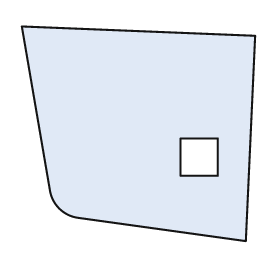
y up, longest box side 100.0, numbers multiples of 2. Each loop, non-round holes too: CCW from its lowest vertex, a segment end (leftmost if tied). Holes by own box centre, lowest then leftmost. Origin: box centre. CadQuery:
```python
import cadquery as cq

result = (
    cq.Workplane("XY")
    .moveTo(46.0, -46.0)
    .lineTo(50.0, 42.0)
    .lineTo(-50.0, 46.0)
    .lineTo(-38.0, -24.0)
    .threePointArc((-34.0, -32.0), (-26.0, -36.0))
    .close()
    .moveTo(18.0, -18.0)
    .lineTo(34.0, -18.0)
    .lineTo(34.0, -2.0)
    .lineTo(18.0, -2.0)
    .close()
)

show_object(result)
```